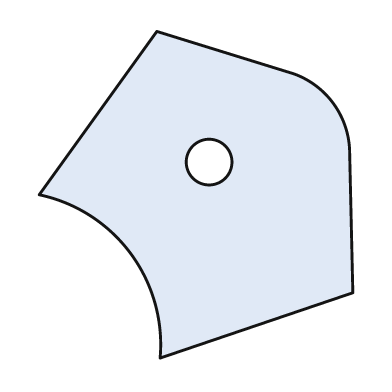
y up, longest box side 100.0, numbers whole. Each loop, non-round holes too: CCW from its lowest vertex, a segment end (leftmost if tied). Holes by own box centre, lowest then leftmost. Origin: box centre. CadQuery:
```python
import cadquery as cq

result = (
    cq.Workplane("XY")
    .moveTo(-11.0, -50.0)
    .lineTo(48.0, -30.0)
    .lineTo(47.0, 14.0)
    .threePointArc((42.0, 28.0), (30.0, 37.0))
    .lineTo(-12.0, 50.0)
    .lineTo(-48.0, 0.0)
    .threePointArc((-20.0, -18.0), (-11.0, -50.0))
    .close()
    .moveTo(4.0, 10.0)
    .circle(7.0)
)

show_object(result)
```